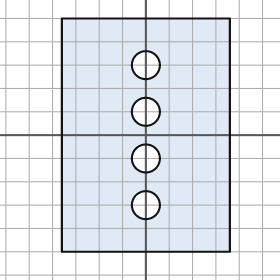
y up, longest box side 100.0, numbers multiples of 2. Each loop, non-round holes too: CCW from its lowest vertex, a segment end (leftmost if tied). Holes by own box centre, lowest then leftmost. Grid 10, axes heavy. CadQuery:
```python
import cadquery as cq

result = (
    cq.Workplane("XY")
    .moveTo(-36.0, -50.0)
    .lineTo(36.0, -50.0)
    .lineTo(36.0, 50.0)
    .lineTo(-36.0, 50.0)
    .close()
    .moveTo(0.0, -30.0)
    .circle(6.0)
    .moveTo(0.0, -10.0)
    .circle(6.0)
    .moveTo(0.0, 10.0)
    .circle(6.0)
    .moveTo(0.0, 30.0)
    .circle(6.0)
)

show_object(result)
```